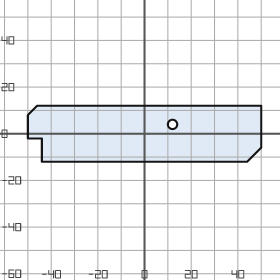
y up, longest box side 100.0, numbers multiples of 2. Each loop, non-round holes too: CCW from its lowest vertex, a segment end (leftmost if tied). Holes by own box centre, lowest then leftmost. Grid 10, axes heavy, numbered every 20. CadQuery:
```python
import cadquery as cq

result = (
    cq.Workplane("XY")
    .moveTo(-44.0, -12.0)
    .lineTo(44.0, -12.0)
    .lineTo(50.0, -6.0)
    .lineTo(50.0, 12.0)
    .lineTo(-46.0, 12.0)
    .lineTo(-50.0, 8.0)
    .lineTo(-50.0, -2.0)
    .lineTo(-44.0, -2.0)
    .close()
    .moveTo(12.0, 4.0)
    .circle(2.0)
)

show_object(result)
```